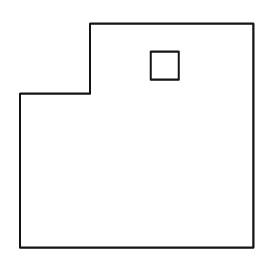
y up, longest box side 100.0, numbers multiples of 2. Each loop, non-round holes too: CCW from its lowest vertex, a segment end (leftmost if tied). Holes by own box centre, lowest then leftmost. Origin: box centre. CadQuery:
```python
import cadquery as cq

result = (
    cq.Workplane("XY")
    .moveTo(-50.0, -48.0)
    .lineTo(50.0, -48.0)
    .lineTo(50.0, 48.0)
    .lineTo(-20.0, 48.0)
    .lineTo(-20.0, 18.0)
    .lineTo(-50.0, 18.0)
    .close()
    .moveTo(6.0, 24.0)
    .lineTo(18.0, 24.0)
    .lineTo(18.0, 36.0)
    .lineTo(6.0, 36.0)
    .close()
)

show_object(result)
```